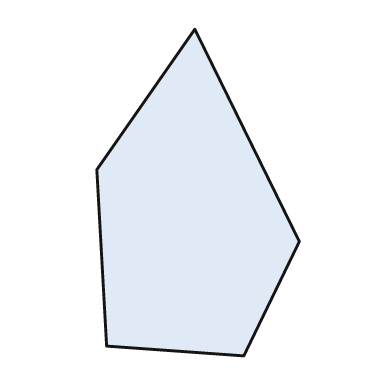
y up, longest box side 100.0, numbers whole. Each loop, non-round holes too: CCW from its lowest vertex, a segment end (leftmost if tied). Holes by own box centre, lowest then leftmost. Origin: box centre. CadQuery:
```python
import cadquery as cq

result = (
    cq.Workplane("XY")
    .moveTo(14.0, -50.0)
    .lineTo(31.0, -15.0)
    .lineTo(-1.0, 50.0)
    .lineTo(-31.0, 7.0)
    .lineTo(-28.0, -47.0)
    .close()
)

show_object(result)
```